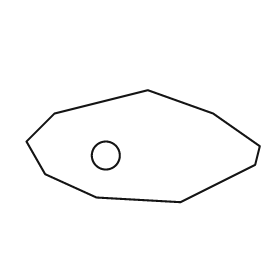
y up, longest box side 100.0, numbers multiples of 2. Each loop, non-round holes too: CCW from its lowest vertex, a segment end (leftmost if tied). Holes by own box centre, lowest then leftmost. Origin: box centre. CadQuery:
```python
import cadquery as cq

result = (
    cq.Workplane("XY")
    .moveTo(16.0, -24.0)
    .lineTo(48.0, -8.0)
    .lineTo(50.0, 0.0)
    .lineTo(30.0, 14.0)
    .lineTo(2.0, 24.0)
    .lineTo(-38.0, 14.0)
    .lineTo(-50.0, 2.0)
    .lineTo(-42.0, -12.0)
    .lineTo(-20.0, -22.0)
    .close()
    .moveTo(-16.0, -4.0)
    .circle(6.0)
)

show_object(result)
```